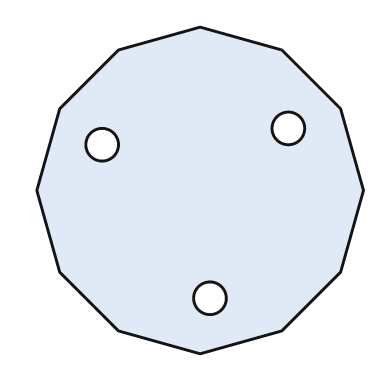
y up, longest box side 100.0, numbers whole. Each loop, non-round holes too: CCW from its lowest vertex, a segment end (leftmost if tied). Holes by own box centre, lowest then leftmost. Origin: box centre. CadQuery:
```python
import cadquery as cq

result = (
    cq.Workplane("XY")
    .moveTo(0.0, -50.0)
    .lineTo(25.0, -43.0)
    .lineTo(43.0, -25.0)
    .lineTo(50.0, 0.0)
    .lineTo(43.0, 25.0)
    .lineTo(25.0, 43.0)
    .lineTo(0.0, 50.0)
    .lineTo(-25.0, 43.0)
    .lineTo(-43.0, 25.0)
    .lineTo(-50.0, 0.0)
    .lineTo(-43.0, -25.0)
    .lineTo(-25.0, -43.0)
    .close()
    .moveTo(3.0, -33.0)
    .circle(5.0)
    .moveTo(-30.0, 14.0)
    .circle(5.0)
    .moveTo(27.0, 19.0)
    .circle(5.0)
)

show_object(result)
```